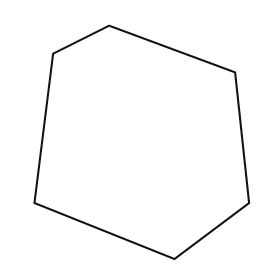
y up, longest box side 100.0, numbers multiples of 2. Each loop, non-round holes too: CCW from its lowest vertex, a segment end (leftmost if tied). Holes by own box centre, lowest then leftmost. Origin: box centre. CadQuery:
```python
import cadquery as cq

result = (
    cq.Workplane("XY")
    .moveTo(14.0, -50.0)
    .lineTo(46.0, -26.0)
    .lineTo(40.0, 30.0)
    .lineTo(-14.0, 50.0)
    .lineTo(-38.0, 38.0)
    .lineTo(-46.0, -26.0)
    .close()
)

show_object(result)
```